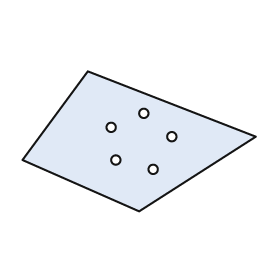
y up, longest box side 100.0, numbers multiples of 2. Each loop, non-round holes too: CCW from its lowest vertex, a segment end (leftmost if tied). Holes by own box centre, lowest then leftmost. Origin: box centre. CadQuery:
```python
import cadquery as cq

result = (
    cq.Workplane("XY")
    .moveTo(0.0, -30.0)
    .lineTo(50.0, 2.0)
    .lineTo(-22.0, 30.0)
    .lineTo(-50.0, -8.0)
    .close()
    .moveTo(6.0, -12.0)
    .circle(2.0)
    .moveTo(-10.0, -8.0)
    .circle(2.0)
    .moveTo(14.0, 2.0)
    .circle(2.0)
    .moveTo(-12.0, 6.0)
    .circle(2.0)
    .moveTo(2.0, 12.0)
    .circle(2.0)
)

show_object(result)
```